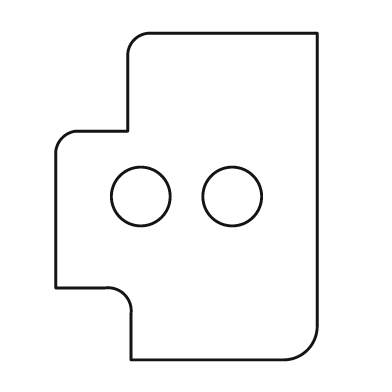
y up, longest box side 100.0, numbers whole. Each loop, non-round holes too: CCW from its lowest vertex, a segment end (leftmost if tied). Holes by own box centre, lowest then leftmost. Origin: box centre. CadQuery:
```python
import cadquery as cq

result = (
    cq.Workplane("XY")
    .moveTo(-17.0, -50.0)
    .lineTo(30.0, -50.0)
    .threePointArc((37.0, -47.0), (40.0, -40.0))
    .lineTo(40.0, 50.0)
    .lineTo(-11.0, 50.0)
    .threePointArc((-16.0, 48.0), (-18.0, 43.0))
    .lineTo(-18.0, 20.0)
    .lineTo(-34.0, 20.0)
    .threePointArc((-38.0, 18.0), (-40.0, 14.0))
    .lineTo(-40.0, -28.0)
    .lineTo(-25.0, -28.0)
    .threePointArc((-19.0, -30.0), (-17.0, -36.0))
    .close()
    .moveTo(-14.0, 0.0)
    .circle(9.0)
    .moveTo(14.0, 0.0)
    .circle(9.0)
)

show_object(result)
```